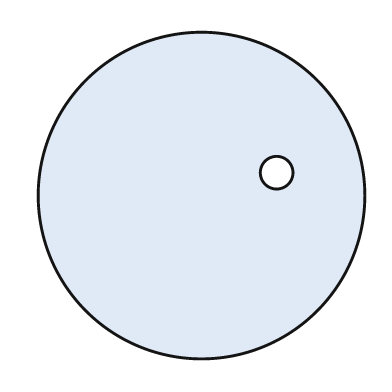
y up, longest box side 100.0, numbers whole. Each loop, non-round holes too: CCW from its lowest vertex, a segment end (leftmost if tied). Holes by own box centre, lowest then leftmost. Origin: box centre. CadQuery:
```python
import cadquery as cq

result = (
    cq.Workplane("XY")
    .moveTo(0.0, 0.0)
    .circle(50.0)
    .moveTo(23.0, 7.0)
    .circle(5.0)
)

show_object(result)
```